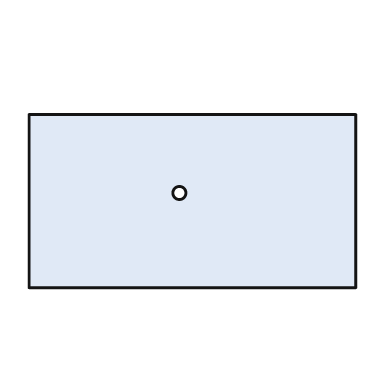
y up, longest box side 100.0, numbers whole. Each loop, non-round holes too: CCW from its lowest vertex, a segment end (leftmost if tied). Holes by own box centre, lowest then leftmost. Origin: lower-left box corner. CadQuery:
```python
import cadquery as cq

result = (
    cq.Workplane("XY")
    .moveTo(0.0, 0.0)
    .lineTo(100.0, 0.0)
    .lineTo(100.0, 53.0)
    .lineTo(0.0, 53.0)
    .close()
    .moveTo(46.0, 29.0)
    .circle(2.0)
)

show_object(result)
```